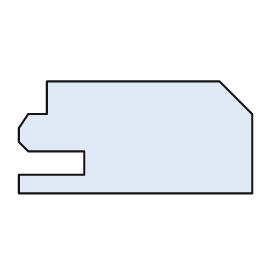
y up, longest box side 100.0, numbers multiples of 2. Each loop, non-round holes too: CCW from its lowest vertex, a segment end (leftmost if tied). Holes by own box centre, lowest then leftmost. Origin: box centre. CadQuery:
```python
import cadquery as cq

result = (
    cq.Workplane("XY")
    .moveTo(-50.0, -24.0)
    .lineTo(50.0, -24.0)
    .lineTo(50.0, 10.0)
    .lineTo(36.0, 24.0)
    .lineTo(-38.0, 24.0)
    .lineTo(-38.0, 10.0)
    .lineTo(-46.0, 10.0)
    .lineTo(-50.0, 4.0)
    .lineTo(-50.0, -2.0)
    .lineTo(-46.0, -6.0)
    .lineTo(-22.0, -6.0)
    .lineTo(-22.0, -16.0)
    .lineTo(-50.0, -16.0)
    .close()
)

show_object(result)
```